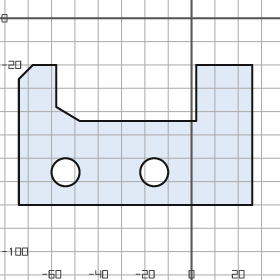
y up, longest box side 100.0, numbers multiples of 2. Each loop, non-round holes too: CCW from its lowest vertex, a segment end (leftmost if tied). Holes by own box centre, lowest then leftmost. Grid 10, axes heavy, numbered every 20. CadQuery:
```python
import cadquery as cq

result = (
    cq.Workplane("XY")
    .moveTo(-74.0, -80.0)
    .lineTo(26.0, -80.0)
    .lineTo(26.0, -20.0)
    .lineTo(2.0, -20.0)
    .lineTo(2.0, -44.0)
    .lineTo(-48.0, -44.0)
    .lineTo(-58.0, -38.0)
    .lineTo(-58.0, -20.0)
    .lineTo(-68.0, -20.0)
    .lineTo(-74.0, -26.0)
    .close()
    .moveTo(-54.0, -66.0)
    .circle(6.0)
    .moveTo(-16.0, -66.0)
    .circle(6.0)
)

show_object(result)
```